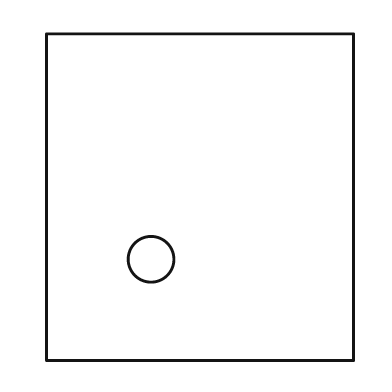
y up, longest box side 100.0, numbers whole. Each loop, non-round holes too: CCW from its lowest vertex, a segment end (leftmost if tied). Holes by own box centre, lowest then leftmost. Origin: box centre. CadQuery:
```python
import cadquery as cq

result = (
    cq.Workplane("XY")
    .moveTo(-47.0, -50.0)
    .lineTo(47.0, -50.0)
    .lineTo(47.0, 50.0)
    .lineTo(-47.0, 50.0)
    .close()
    .moveTo(-15.0, -19.0)
    .circle(7.0)
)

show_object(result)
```